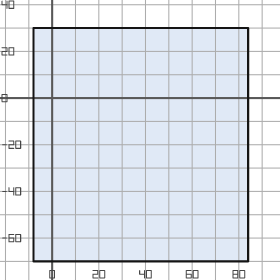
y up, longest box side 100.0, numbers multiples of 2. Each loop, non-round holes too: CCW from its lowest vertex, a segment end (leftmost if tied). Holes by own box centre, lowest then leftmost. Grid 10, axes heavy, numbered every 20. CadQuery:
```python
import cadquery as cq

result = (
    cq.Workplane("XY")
    .moveTo(-8.0, -70.0)
    .lineTo(84.0, -70.0)
    .lineTo(84.0, 30.0)
    .lineTo(-8.0, 30.0)
    .close()
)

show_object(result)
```